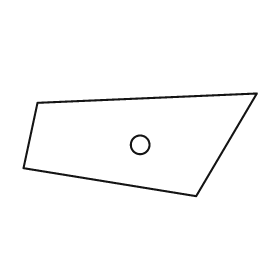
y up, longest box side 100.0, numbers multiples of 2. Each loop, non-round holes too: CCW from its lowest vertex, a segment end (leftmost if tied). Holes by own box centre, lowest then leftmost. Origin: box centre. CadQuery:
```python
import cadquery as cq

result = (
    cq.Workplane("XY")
    .moveTo(24.0, -22.0)
    .lineTo(50.0, 22.0)
    .lineTo(-44.0, 18.0)
    .lineTo(-50.0, -10.0)
    .close()
    .moveTo(0.0, 0.0)
    .circle(4.0)
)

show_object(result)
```